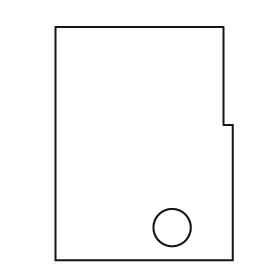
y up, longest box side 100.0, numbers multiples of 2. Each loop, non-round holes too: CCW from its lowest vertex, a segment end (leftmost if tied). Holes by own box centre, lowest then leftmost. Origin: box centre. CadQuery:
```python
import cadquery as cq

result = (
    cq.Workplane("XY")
    .moveTo(-38.0, -50.0)
    .lineTo(38.0, -50.0)
    .lineTo(38.0, 8.0)
    .lineTo(34.0, 8.0)
    .lineTo(34.0, 50.0)
    .lineTo(-38.0, 50.0)
    .close()
    .moveTo(12.0, -36.0)
    .circle(8.0)
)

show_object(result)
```